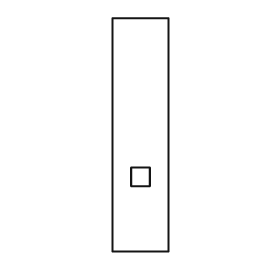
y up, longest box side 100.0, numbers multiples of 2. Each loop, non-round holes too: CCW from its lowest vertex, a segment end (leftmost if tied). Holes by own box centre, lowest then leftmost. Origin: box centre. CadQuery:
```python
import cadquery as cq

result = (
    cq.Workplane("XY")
    .moveTo(-12.0, -50.0)
    .lineTo(12.0, -50.0)
    .lineTo(12.0, 50.0)
    .lineTo(-12.0, 50.0)
    .close()
    .moveTo(-4.0, -22.0)
    .lineTo(4.0, -22.0)
    .lineTo(4.0, -14.0)
    .lineTo(-4.0, -14.0)
    .close()
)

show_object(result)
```